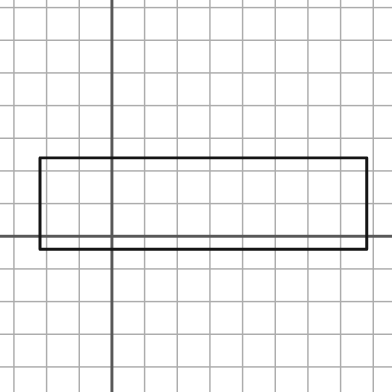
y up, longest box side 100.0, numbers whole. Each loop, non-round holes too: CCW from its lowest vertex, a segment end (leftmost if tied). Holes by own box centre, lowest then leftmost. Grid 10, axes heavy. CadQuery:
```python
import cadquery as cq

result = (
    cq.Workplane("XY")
    .moveTo(-22.0, -4.0)
    .lineTo(78.0, -4.0)
    .lineTo(78.0, 24.0)
    .lineTo(-22.0, 24.0)
    .close()
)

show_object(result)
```